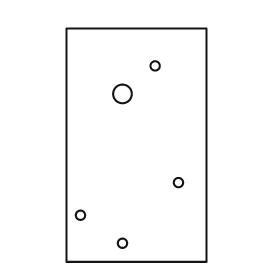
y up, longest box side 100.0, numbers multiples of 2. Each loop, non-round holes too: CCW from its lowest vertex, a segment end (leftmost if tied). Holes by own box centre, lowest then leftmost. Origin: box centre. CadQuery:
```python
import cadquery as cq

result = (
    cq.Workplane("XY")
    .moveTo(-30.0, -50.0)
    .lineTo(30.0, -50.0)
    .lineTo(30.0, 50.0)
    .lineTo(-30.0, 50.0)
    .close()
    .moveTo(-6.0, -42.0)
    .circle(2.0)
    .moveTo(-24.0, -30.0)
    .circle(2.0)
    .moveTo(18.0, -16.0)
    .circle(2.0)
    .moveTo(-6.0, 22.0)
    .circle(4.0)
    .moveTo(8.0, 34.0)
    .circle(2.0)
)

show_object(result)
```